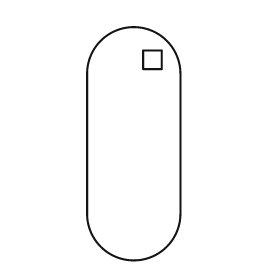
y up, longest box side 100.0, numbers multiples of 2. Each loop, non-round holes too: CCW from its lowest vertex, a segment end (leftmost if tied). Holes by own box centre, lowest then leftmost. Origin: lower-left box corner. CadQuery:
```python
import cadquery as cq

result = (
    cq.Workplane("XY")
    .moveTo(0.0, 20.0)
    .threePointArc((20.0, 0.0), (40.0, 20.0))
    .lineTo(40.0, 80.0)
    .threePointArc((20.0, 100.0), (0.0, 80.0))
    .close()
    .moveTo(24.0, 82.0)
    .lineTo(32.0, 82.0)
    .lineTo(32.0, 90.0)
    .lineTo(24.0, 90.0)
    .close()
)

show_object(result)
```